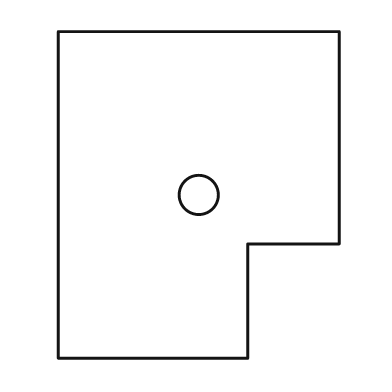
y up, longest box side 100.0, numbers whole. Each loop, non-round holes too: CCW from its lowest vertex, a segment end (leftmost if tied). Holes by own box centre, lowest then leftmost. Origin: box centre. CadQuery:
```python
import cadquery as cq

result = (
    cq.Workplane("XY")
    .moveTo(-43.0, -50.0)
    .lineTo(15.0, -50.0)
    .lineTo(15.0, -15.0)
    .lineTo(43.0, -15.0)
    .lineTo(43.0, 50.0)
    .lineTo(-43.0, 50.0)
    .close()
    .moveTo(0.0, 0.0)
    .circle(6.0)
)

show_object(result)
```